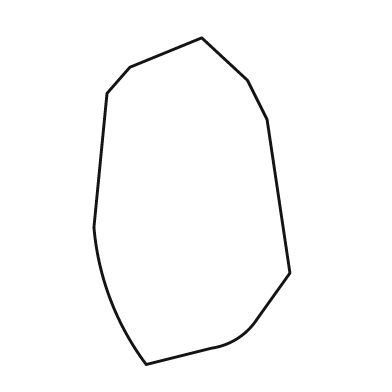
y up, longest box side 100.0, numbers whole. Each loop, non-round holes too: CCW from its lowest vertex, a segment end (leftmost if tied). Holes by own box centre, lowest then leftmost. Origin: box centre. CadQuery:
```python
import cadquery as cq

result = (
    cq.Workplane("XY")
    .moveTo(-14.0, -50.0)
    .lineTo(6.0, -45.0)
    .threePointArc((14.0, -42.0), (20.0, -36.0))
    .lineTo(30.0, -22.0)
    .lineTo(23.0, 25.0)
    .lineTo(17.0, 37.0)
    .lineTo(3.0, 50.0)
    .lineTo(-19.0, 41.0)
    .lineTo(-26.0, 33.0)
    .lineTo(-30.0, -8.0)
    .threePointArc((-25.0, -30.0), (-14.0, -50.0))
    .close()
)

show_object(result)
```